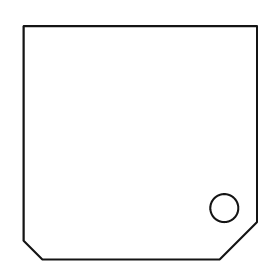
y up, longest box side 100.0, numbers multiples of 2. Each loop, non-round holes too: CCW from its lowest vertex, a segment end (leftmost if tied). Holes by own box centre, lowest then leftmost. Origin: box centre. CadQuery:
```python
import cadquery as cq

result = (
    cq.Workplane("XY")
    .moveTo(-42.0, -50.0)
    .lineTo(34.0, -50.0)
    .lineTo(50.0, -34.0)
    .lineTo(50.0, 50.0)
    .lineTo(-50.0, 50.0)
    .lineTo(-50.0, -42.0)
    .close()
    .moveTo(36.0, -28.0)
    .circle(6.0)
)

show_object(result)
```